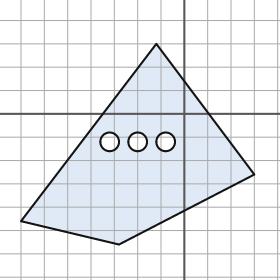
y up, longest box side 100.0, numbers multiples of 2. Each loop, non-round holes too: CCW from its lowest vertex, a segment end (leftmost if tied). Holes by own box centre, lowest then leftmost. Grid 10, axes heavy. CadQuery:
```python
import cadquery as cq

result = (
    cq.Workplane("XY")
    .moveTo(-28.0, -56.0)
    .lineTo(30.0, -26.0)
    .lineTo(-12.0, 30.0)
    .lineTo(-70.0, -46.0)
    .close()
    .moveTo(-32.0, -12.0)
    .circle(4.0)
    .moveTo(-20.0, -12.0)
    .circle(4.0)
    .moveTo(-8.0, -12.0)
    .circle(4.0)
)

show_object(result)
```